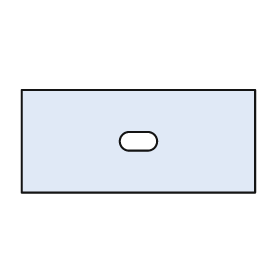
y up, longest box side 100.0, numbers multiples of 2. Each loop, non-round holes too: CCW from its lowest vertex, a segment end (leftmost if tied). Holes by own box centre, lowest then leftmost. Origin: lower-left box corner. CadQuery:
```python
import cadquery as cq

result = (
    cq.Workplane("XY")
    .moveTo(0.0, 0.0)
    .lineTo(100.0, 0.0)
    .lineTo(100.0, 44.0)
    .lineTo(0.0, 44.0)
    .close()
    .moveTo(46.0, 18.0)
    .lineTo(54.0, 18.0)
    .threePointArc((58.0, 22.0), (54.0, 26.0))
    .lineTo(46.0, 26.0)
    .threePointArc((42.0, 22.0), (46.0, 18.0))
    .close()
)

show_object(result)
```